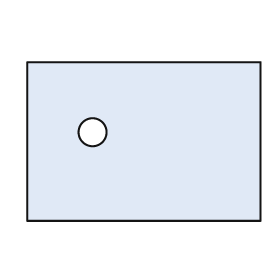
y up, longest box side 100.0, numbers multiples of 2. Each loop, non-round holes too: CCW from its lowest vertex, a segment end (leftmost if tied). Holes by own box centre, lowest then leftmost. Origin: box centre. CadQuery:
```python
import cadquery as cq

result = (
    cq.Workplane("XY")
    .moveTo(-50.0, -34.0)
    .lineTo(50.0, -34.0)
    .lineTo(50.0, 34.0)
    .lineTo(-50.0, 34.0)
    .close()
    .moveTo(-22.0, 4.0)
    .circle(6.0)
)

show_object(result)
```